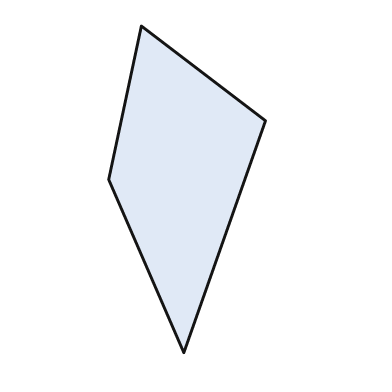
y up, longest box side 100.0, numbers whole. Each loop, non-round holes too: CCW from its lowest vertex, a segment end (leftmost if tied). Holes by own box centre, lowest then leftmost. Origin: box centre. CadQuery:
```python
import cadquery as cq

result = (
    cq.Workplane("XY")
    .moveTo(-1.0, -50.0)
    .lineTo(24.0, 21.0)
    .lineTo(-14.0, 50.0)
    .lineTo(-24.0, 3.0)
    .close()
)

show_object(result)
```